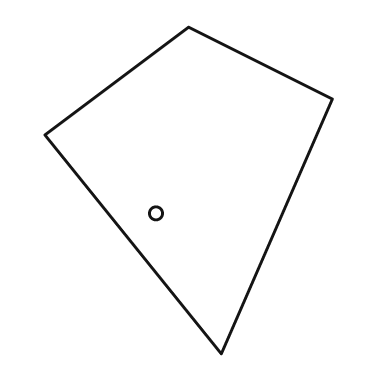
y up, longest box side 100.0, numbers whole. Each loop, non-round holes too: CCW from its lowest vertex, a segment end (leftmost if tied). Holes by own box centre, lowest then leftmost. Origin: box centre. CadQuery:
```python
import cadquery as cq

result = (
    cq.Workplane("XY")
    .moveTo(10.0, -50.0)
    .lineTo(44.0, 28.0)
    .lineTo(0.0, 50.0)
    .lineTo(-44.0, 17.0)
    .close()
    .moveTo(-10.0, -7.0)
    .circle(2.0)
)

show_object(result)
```